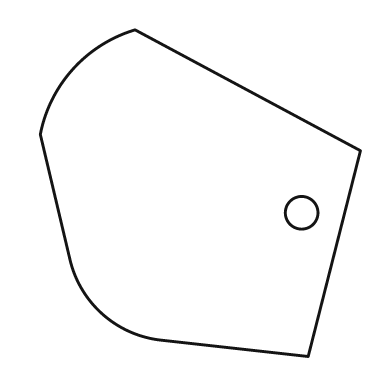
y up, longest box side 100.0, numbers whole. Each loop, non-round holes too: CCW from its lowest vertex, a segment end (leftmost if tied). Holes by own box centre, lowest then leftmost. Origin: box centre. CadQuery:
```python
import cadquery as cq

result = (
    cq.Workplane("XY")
    .moveTo(33.0, -50.0)
    .lineTo(49.0, 13.0)
    .lineTo(-20.0, 50.0)
    .threePointArc((-39.0, 38.0), (-49.0, 18.0))
    .lineTo(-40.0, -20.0)
    .threePointArc((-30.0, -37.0), (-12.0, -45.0))
    .close()
    .moveTo(31.0, -6.0)
    .circle(5.0)
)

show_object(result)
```